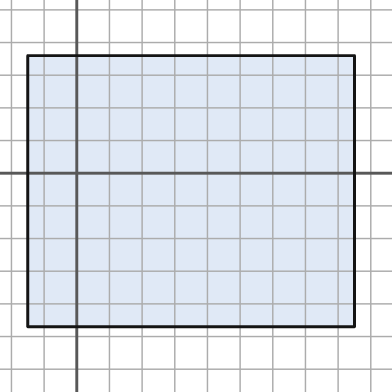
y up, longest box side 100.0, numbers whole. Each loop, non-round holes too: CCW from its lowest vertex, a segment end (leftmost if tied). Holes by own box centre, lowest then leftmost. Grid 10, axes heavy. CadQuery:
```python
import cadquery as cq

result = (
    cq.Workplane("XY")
    .moveTo(-15.0, -47.0)
    .lineTo(85.0, -47.0)
    .lineTo(85.0, 36.0)
    .lineTo(-15.0, 36.0)
    .close()
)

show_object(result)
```